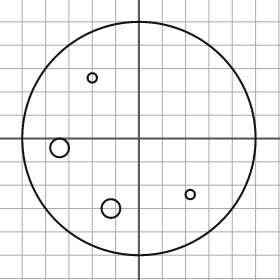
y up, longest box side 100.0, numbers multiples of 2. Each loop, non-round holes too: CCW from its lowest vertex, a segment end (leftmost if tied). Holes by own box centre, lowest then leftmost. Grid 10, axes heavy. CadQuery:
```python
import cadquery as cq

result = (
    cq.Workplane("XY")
    .moveTo(0.0, 0.0)
    .circle(50.0)
    .moveTo(-12.0, -30.0)
    .circle(4.0)
    .moveTo(22.0, -24.0)
    .circle(2.0)
    .moveTo(-34.0, -4.0)
    .circle(4.0)
    .moveTo(-20.0, 26.0)
    .circle(2.0)
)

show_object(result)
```